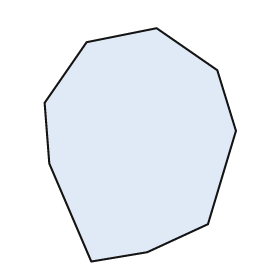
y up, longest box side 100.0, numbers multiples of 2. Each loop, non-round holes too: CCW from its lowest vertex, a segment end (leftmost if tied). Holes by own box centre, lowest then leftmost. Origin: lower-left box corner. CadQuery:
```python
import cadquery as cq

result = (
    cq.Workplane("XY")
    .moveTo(20.0, 0.0)
    .lineTo(44.0, 4.0)
    .lineTo(70.0, 16.0)
    .lineTo(82.0, 56.0)
    .lineTo(74.0, 82.0)
    .lineTo(48.0, 100.0)
    .lineTo(18.0, 94.0)
    .lineTo(0.0, 68.0)
    .lineTo(2.0, 42.0)
    .close()
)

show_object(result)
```